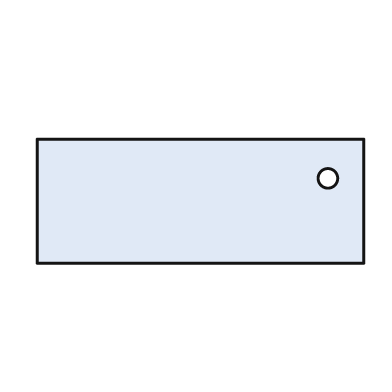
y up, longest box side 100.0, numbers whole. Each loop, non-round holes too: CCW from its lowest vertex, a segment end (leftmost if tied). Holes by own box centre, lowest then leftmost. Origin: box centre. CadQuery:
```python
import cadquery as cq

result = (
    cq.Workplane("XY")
    .moveTo(-50.0, -19.0)
    .lineTo(50.0, -19.0)
    .lineTo(50.0, 19.0)
    .lineTo(-50.0, 19.0)
    .close()
    .moveTo(39.0, 7.0)
    .circle(3.0)
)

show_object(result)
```